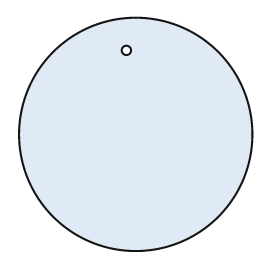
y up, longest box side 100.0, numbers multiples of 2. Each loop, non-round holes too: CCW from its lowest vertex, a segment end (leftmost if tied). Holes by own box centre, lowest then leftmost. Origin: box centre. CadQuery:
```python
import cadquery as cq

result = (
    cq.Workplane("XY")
    .moveTo(0.0, 0.0)
    .circle(50.0)
    .moveTo(-4.0, 36.0)
    .circle(2.0)
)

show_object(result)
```